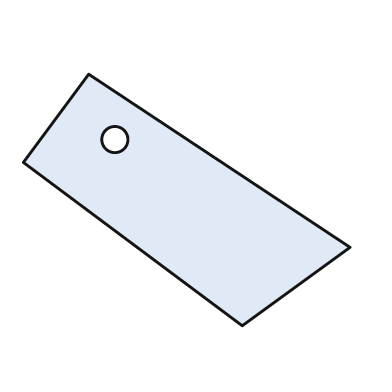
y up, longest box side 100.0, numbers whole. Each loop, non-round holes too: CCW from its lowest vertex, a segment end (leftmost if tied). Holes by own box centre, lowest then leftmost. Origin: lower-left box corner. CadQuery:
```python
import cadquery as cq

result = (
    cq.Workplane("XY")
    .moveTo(67.0, 0.0)
    .lineTo(100.0, 24.0)
    .lineTo(20.0, 77.0)
    .lineTo(0.0, 50.0)
    .close()
    .moveTo(28.0, 57.0)
    .circle(4.0)
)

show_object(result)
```